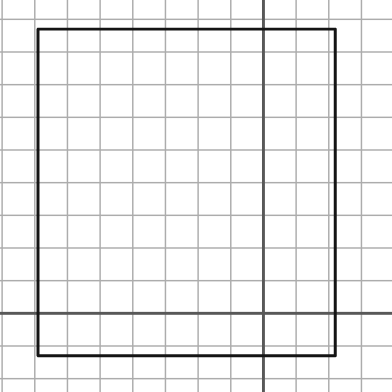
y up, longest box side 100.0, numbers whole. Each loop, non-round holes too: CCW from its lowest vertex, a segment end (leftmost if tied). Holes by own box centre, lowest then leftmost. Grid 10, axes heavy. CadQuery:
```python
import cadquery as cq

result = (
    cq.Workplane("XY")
    .moveTo(-69.0, -13.0)
    .lineTo(22.0, -13.0)
    .lineTo(22.0, 87.0)
    .lineTo(-69.0, 87.0)
    .close()
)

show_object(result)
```